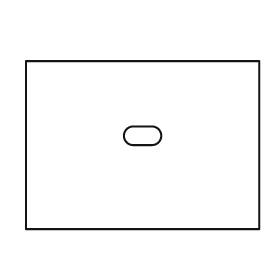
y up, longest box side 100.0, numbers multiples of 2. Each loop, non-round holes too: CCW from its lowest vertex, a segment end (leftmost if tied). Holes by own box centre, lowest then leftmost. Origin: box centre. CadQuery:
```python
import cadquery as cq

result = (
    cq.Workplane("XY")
    .moveTo(-50.0, -36.0)
    .lineTo(50.0, -36.0)
    .lineTo(50.0, 36.0)
    .lineTo(-50.0, 36.0)
    .close()
    .moveTo(-4.0, 0.0)
    .lineTo(4.0, 0.0)
    .threePointArc((8.0, 4.0), (4.0, 8.0))
    .lineTo(-4.0, 8.0)
    .threePointArc((-8.0, 4.0), (-4.0, 0.0))
    .close()
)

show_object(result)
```